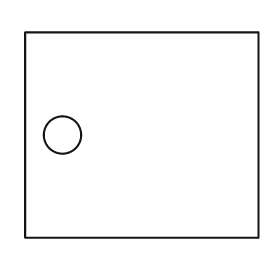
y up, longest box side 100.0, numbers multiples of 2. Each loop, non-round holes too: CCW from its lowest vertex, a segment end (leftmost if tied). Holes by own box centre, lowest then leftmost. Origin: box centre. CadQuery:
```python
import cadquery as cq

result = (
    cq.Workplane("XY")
    .moveTo(-50.0, -44.0)
    .lineTo(50.0, -44.0)
    .lineTo(50.0, 44.0)
    .lineTo(-50.0, 44.0)
    .close()
    .moveTo(-34.0, 0.0)
    .circle(8.0)
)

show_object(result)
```